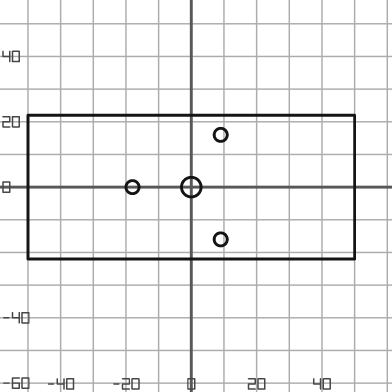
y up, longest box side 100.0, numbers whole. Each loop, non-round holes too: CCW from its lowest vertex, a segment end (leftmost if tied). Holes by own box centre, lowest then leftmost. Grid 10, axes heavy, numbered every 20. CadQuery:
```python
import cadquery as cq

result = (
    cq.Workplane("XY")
    .moveTo(-50.0, -22.0)
    .lineTo(50.0, -22.0)
    .lineTo(50.0, 22.0)
    .lineTo(-50.0, 22.0)
    .close()
    .moveTo(9.0, -16.0)
    .circle(2.0)
    .moveTo(-18.0, 0.0)
    .circle(2.0)
    .moveTo(0.0, 0.0)
    .circle(3.0)
    .moveTo(9.0, 16.0)
    .circle(2.0)
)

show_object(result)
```